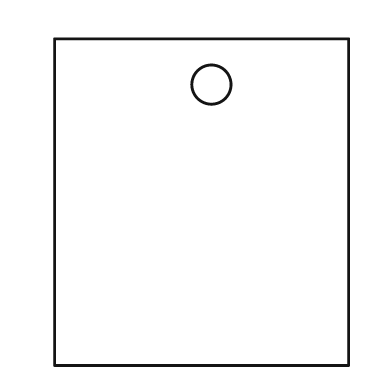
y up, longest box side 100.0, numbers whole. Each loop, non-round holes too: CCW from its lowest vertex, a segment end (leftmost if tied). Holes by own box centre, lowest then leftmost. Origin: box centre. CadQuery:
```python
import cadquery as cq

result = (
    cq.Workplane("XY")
    .moveTo(-45.0, -50.0)
    .lineTo(45.0, -50.0)
    .lineTo(45.0, 50.0)
    .lineTo(-45.0, 50.0)
    .close()
    .moveTo(3.0, 36.0)
    .circle(6.0)
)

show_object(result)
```